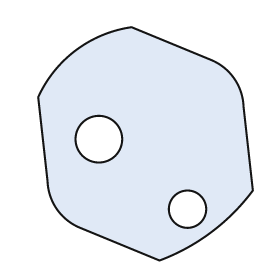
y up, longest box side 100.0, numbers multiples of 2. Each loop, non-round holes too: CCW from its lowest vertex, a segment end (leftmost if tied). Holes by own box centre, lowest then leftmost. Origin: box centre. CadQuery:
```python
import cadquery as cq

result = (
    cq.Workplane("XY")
    .moveTo(6.0, -50.0)
    .threePointArc((28.0, -38.0), (46.0, -20.0))
    .lineTo(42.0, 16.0)
    .threePointArc((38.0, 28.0), (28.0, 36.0))
    .lineTo(-6.0, 50.0)
    .threePointArc((-30.0, 40.0), (-46.0, 20.0))
    .lineTo(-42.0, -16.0)
    .threePointArc((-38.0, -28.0), (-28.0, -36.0))
    .close()
    .moveTo(18.0, -28.0)
    .circle(8.0)
    .moveTo(-20.0, 2.0)
    .circle(10.0)
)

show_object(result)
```